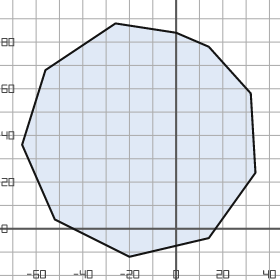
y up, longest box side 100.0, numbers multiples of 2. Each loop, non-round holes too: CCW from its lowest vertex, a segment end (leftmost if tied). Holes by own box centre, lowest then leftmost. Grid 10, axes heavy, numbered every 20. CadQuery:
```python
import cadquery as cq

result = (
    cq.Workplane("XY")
    .moveTo(-20.0, -12.0)
    .lineTo(14.0, -4.0)
    .lineTo(34.0, 24.0)
    .lineTo(32.0, 58.0)
    .lineTo(14.0, 78.0)
    .lineTo(0.0, 84.0)
    .lineTo(-26.0, 88.0)
    .lineTo(-56.0, 68.0)
    .lineTo(-66.0, 36.0)
    .lineTo(-52.0, 4.0)
    .close()
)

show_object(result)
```